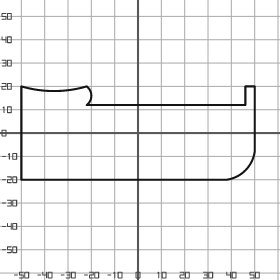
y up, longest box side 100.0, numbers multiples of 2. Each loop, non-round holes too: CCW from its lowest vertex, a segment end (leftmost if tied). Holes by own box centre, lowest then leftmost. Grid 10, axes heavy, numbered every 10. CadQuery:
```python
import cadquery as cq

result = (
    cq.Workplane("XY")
    .moveTo(-50.0, -20.0)
    .lineTo(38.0, -20.0)
    .threePointArc((46.0, -16.0), (50.0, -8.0))
    .lineTo(50.0, 20.0)
    .lineTo(46.0, 20.0)
    .lineTo(46.0, 12.0)
    .lineTo(-22.0, 12.0)
    .threePointArc((-20.0, 16.0), (-22.0, 20.0))
    .threePointArc((-36.0, 18.0), (-50.0, 20.0))
    .close()
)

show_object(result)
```